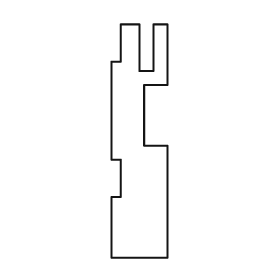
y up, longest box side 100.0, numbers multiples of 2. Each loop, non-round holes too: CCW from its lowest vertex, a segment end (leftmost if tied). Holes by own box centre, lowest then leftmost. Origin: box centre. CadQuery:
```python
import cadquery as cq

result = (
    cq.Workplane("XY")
    .moveTo(-12.0, -50.0)
    .lineTo(12.0, -50.0)
    .lineTo(12.0, -2.0)
    .lineTo(2.0, -2.0)
    .lineTo(2.0, 24.0)
    .lineTo(12.0, 24.0)
    .lineTo(12.0, 50.0)
    .lineTo(6.0, 50.0)
    .lineTo(6.0, 30.0)
    .lineTo(0.0, 30.0)
    .lineTo(0.0, 50.0)
    .lineTo(-8.0, 50.0)
    .lineTo(-8.0, 34.0)
    .lineTo(-12.0, 34.0)
    .lineTo(-12.0, -8.0)
    .lineTo(-8.0, -8.0)
    .lineTo(-8.0, -24.0)
    .lineTo(-12.0, -24.0)
    .close()
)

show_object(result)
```